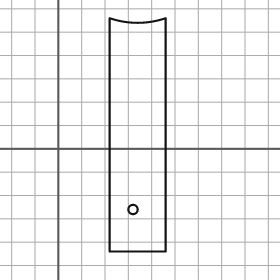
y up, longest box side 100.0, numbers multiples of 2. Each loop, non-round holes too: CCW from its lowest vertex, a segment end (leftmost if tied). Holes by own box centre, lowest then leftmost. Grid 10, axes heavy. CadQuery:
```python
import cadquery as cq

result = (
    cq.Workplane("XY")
    .moveTo(22.0, -44.0)
    .lineTo(46.0, -44.0)
    .lineTo(46.0, 56.0)
    .threePointArc((34.0, 54.0), (22.0, 56.0))
    .close()
    .moveTo(32.0, -26.0)
    .circle(2.0)
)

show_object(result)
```